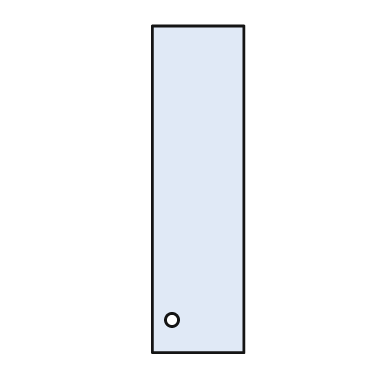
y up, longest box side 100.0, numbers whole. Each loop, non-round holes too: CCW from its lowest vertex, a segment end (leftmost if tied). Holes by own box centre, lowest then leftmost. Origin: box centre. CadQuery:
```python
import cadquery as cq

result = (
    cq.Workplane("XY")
    .moveTo(-14.0, -50.0)
    .lineTo(14.0, -50.0)
    .lineTo(14.0, 50.0)
    .lineTo(-14.0, 50.0)
    .close()
    .moveTo(-8.0, -40.0)
    .circle(2.0)
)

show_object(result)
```